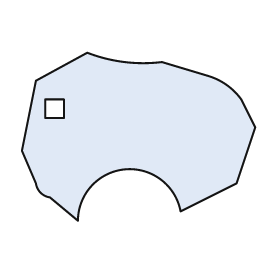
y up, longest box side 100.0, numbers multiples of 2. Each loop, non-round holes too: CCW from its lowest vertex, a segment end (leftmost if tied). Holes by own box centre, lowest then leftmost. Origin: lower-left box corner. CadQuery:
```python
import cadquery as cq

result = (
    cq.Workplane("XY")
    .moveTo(24.0, 0.0)
    .threePointArc((44.0, 22.0), (68.0, 4.0))
    .lineTo(92.0, 16.0)
    .lineTo(100.0, 40.0)
    .lineTo(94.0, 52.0)
    .threePointArc((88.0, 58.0), (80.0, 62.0))
    .lineTo(60.0, 68.0)
    .threePointArc((44.0, 68.0), (28.0, 72.0))
    .lineTo(6.0, 60.0)
    .lineTo(0.0, 30.0)
    .lineTo(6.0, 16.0)
    .threePointArc((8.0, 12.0), (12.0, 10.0))
    .close()
    .moveTo(10.0, 44.0)
    .lineTo(18.0, 44.0)
    .lineTo(18.0, 52.0)
    .lineTo(10.0, 52.0)
    .close()
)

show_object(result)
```